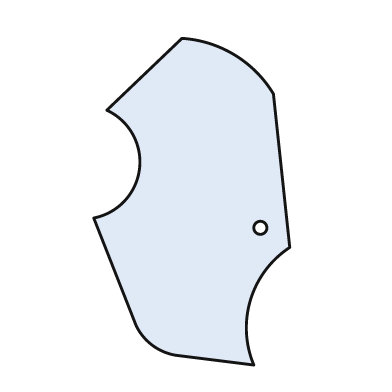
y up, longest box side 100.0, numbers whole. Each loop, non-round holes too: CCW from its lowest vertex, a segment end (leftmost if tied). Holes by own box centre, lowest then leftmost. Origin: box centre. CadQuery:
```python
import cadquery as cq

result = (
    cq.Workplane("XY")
    .moveTo(19.0, -50.0)
    .threePointArc((18.0, -30.0), (30.0, -14.0))
    .lineTo(25.0, 33.0)
    .threePointArc((13.0, 45.0), (-3.0, 50.0))
    .lineTo(-26.0, 28.0)
    .threePointArc((-16.0, 10.0), (-30.0, -5.0))
    .lineTo(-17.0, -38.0)
    .threePointArc((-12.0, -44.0), (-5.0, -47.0))
    .close()
    .moveTo(21.0, -8.0)
    .circle(2.0)
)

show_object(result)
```